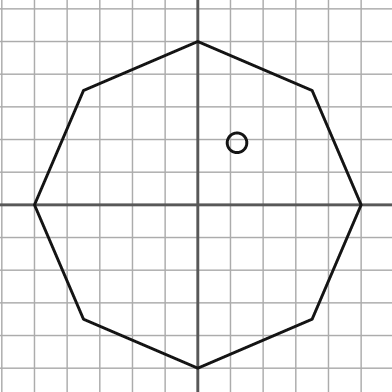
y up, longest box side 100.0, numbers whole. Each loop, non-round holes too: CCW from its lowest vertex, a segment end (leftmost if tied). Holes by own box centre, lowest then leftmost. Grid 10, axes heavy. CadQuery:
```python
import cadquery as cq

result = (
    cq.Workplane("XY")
    .moveTo(0.0, -50.0)
    .lineTo(35.0, -35.0)
    .lineTo(50.0, 0.0)
    .lineTo(35.0, 35.0)
    .lineTo(0.0, 50.0)
    .lineTo(-35.0, 35.0)
    .lineTo(-50.0, 0.0)
    .lineTo(-35.0, -35.0)
    .close()
    .moveTo(12.0, 19.0)
    .circle(3.0)
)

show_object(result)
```